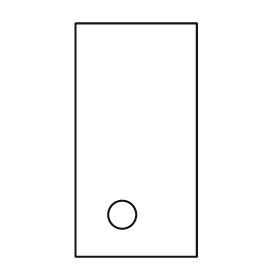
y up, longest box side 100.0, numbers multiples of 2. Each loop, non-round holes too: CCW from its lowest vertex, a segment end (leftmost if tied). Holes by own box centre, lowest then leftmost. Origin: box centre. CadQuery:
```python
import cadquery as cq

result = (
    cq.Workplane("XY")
    .moveTo(-26.0, -50.0)
    .lineTo(26.0, -50.0)
    .lineTo(26.0, 50.0)
    .lineTo(-26.0, 50.0)
    .close()
    .moveTo(-6.0, -32.0)
    .circle(6.0)
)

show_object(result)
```